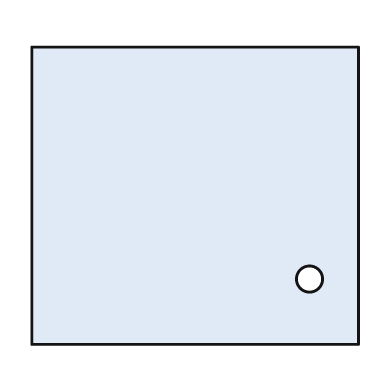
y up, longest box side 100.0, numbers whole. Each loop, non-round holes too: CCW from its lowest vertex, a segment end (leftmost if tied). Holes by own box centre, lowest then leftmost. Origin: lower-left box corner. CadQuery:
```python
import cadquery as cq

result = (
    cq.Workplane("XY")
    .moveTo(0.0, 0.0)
    .lineTo(100.0, 0.0)
    .lineTo(100.0, 91.0)
    .lineTo(0.0, 91.0)
    .close()
    .moveTo(85.0, 20.0)
    .circle(4.0)
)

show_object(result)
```